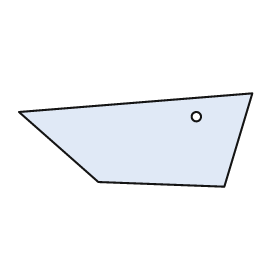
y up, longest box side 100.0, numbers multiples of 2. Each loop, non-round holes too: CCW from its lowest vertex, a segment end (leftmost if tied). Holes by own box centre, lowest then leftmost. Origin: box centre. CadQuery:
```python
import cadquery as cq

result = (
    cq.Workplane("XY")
    .moveTo(38.0, -20.0)
    .lineTo(50.0, 20.0)
    .lineTo(-50.0, 12.0)
    .lineTo(-16.0, -18.0)
    .close()
    .moveTo(26.0, 10.0)
    .circle(2.0)
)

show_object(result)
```